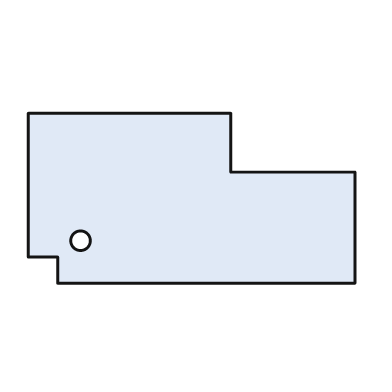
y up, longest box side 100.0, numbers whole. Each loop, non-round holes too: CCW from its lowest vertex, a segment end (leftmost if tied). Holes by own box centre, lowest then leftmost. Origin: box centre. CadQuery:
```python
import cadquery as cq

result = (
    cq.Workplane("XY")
    .moveTo(-41.0, -26.0)
    .lineTo(50.0, -26.0)
    .lineTo(50.0, 8.0)
    .lineTo(12.0, 8.0)
    .lineTo(12.0, 26.0)
    .lineTo(-50.0, 26.0)
    .lineTo(-50.0, -18.0)
    .lineTo(-41.0, -18.0)
    .close()
    .moveTo(-34.0, -13.0)
    .circle(3.0)
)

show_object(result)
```